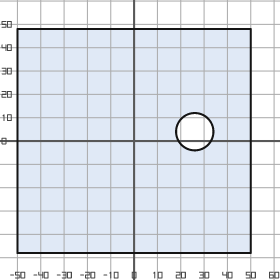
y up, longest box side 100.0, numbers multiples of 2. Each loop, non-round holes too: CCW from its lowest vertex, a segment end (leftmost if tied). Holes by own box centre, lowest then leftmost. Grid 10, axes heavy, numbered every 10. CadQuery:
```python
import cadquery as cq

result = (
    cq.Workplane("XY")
    .moveTo(-50.0, -48.0)
    .lineTo(50.0, -48.0)
    .lineTo(50.0, 48.0)
    .lineTo(-50.0, 48.0)
    .close()
    .moveTo(26.0, 4.0)
    .circle(8.0)
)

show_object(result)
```